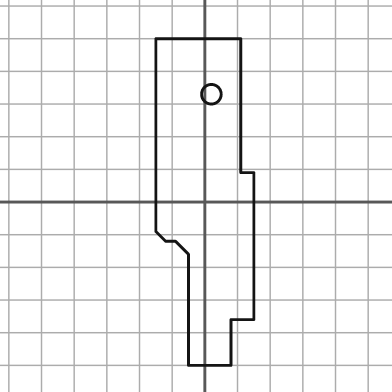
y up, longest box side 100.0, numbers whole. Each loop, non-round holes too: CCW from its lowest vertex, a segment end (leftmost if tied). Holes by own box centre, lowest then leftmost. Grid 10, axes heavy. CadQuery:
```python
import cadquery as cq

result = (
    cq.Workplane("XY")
    .moveTo(-5.0, -50.0)
    .lineTo(8.0, -50.0)
    .lineTo(8.0, -36.0)
    .lineTo(15.0, -36.0)
    .lineTo(15.0, 9.0)
    .lineTo(11.0, 9.0)
    .lineTo(11.0, 50.0)
    .lineTo(-15.0, 50.0)
    .lineTo(-15.0, -9.0)
    .lineTo(-12.0, -12.0)
    .lineTo(-9.0, -12.0)
    .lineTo(-5.0, -16.0)
    .close()
    .moveTo(2.0, 33.0)
    .circle(3.0)
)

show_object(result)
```